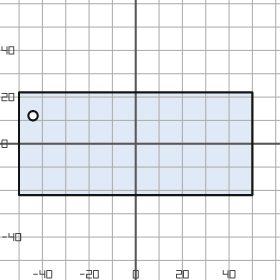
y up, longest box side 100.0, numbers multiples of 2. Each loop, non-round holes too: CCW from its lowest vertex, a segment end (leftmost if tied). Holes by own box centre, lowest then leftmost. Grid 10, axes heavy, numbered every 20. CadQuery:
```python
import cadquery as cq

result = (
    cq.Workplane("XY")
    .moveTo(-50.0, -22.0)
    .lineTo(50.0, -22.0)
    .lineTo(50.0, 22.0)
    .lineTo(-50.0, 22.0)
    .close()
    .moveTo(-44.0, 12.0)
    .circle(2.0)
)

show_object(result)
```